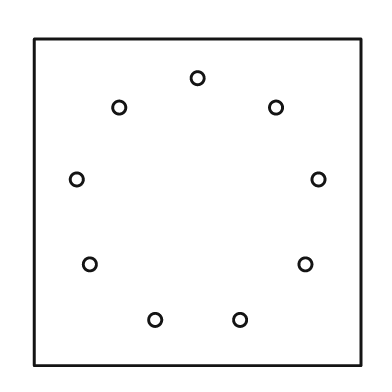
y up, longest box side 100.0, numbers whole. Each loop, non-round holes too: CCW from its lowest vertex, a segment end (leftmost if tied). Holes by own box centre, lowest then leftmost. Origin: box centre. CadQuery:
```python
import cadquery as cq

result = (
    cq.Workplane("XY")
    .moveTo(-50.0, -50.0)
    .lineTo(50.0, -50.0)
    .lineTo(50.0, 50.0)
    .lineTo(-50.0, 50.0)
    .close()
    .moveTo(-13.0, -36.0)
    .circle(2.0)
    .moveTo(13.0, -36.0)
    .circle(2.0)
    .moveTo(-33.0, -19.0)
    .circle(2.0)
    .moveTo(33.0, -19.0)
    .circle(2.0)
    .moveTo(-37.0, 7.0)
    .circle(2.0)
    .moveTo(37.0, 7.0)
    .circle(2.0)
    .moveTo(-24.0, 29.0)
    .circle(2.0)
    .moveTo(24.0, 29.0)
    .circle(2.0)
    .moveTo(0.0, 38.0)
    .circle(2.0)
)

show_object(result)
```